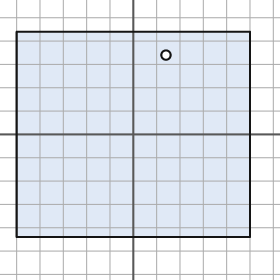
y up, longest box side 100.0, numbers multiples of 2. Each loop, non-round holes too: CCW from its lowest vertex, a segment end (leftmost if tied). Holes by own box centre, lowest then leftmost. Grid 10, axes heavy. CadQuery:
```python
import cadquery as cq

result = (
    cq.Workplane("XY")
    .moveTo(-50.0, -44.0)
    .lineTo(50.0, -44.0)
    .lineTo(50.0, 44.0)
    .lineTo(-50.0, 44.0)
    .close()
    .moveTo(14.0, 34.0)
    .circle(2.0)
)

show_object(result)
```